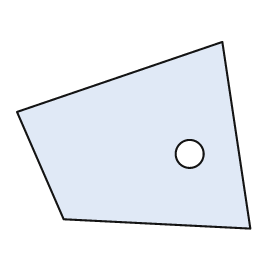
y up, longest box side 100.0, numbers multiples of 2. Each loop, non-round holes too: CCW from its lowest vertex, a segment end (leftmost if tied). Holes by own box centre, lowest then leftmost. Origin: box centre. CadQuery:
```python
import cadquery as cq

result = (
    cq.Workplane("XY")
    .moveTo(50.0, -40.0)
    .lineTo(38.0, 40.0)
    .lineTo(-50.0, 10.0)
    .lineTo(-30.0, -36.0)
    .close()
    .moveTo(24.0, -8.0)
    .circle(6.0)
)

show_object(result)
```